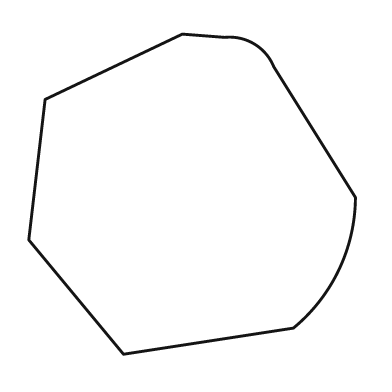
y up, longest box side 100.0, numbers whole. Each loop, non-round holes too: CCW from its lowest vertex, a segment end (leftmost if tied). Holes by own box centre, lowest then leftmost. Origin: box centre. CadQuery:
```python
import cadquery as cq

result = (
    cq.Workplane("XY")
    .moveTo(-21.0, -49.0)
    .lineTo(31.0, -41.0)
    .threePointArc((45.0, -23.0), (50.0, -1.0))
    .lineTo(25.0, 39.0)
    .threePointArc((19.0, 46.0), (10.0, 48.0))
    .lineTo(-3.0, 49.0)
    .lineTo(-45.0, 29.0)
    .lineTo(-50.0, -14.0)
    .close()
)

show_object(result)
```